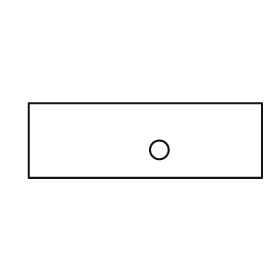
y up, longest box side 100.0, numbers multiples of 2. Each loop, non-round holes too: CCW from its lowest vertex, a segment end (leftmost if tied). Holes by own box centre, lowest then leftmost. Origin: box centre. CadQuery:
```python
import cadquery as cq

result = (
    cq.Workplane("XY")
    .moveTo(-50.0, -16.0)
    .lineTo(50.0, -16.0)
    .lineTo(50.0, 16.0)
    .lineTo(-50.0, 16.0)
    .close()
    .moveTo(6.0, -4.0)
    .circle(4.0)
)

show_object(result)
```